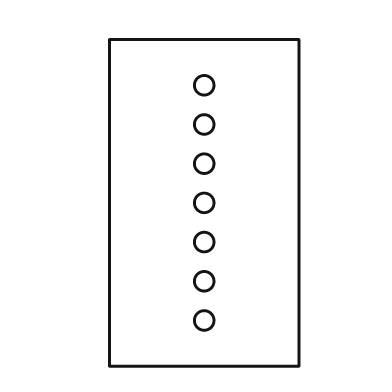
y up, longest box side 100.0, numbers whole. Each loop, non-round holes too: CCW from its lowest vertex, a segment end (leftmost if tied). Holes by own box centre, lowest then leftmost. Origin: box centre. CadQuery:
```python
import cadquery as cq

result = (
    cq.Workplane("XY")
    .moveTo(-29.0, -50.0)
    .lineTo(29.0, -50.0)
    .lineTo(29.0, 50.0)
    .lineTo(-29.0, 50.0)
    .close()
    .moveTo(0.0, -36.0)
    .circle(3.0)
    .moveTo(0.0, -24.0)
    .circle(3.0)
    .moveTo(0.0, -12.0)
    .circle(3.0)
    .moveTo(0.0, 0.0)
    .circle(3.0)
    .moveTo(0.0, 12.0)
    .circle(3.0)
    .moveTo(0.0, 24.0)
    .circle(3.0)
    .moveTo(0.0, 36.0)
    .circle(3.0)
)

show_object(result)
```